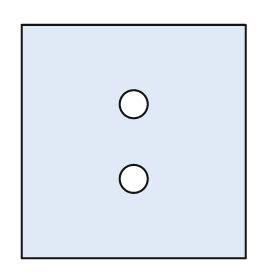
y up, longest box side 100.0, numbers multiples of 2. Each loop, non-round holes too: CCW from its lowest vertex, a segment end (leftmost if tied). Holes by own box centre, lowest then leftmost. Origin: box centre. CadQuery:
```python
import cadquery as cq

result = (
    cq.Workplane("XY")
    .moveTo(-48.0, -50.0)
    .lineTo(48.0, -50.0)
    .lineTo(48.0, 50.0)
    .lineTo(-48.0, 50.0)
    .close()
    .moveTo(0.0, -16.0)
    .circle(6.0)
    .moveTo(0.0, 16.0)
    .circle(6.0)
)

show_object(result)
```